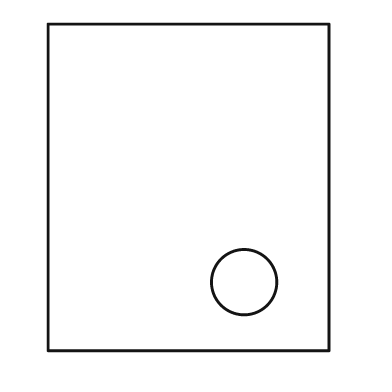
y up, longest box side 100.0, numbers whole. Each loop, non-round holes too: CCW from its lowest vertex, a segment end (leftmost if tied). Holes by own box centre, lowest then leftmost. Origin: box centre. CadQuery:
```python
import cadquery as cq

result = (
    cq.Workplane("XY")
    .moveTo(-43.0, -50.0)
    .lineTo(43.0, -50.0)
    .lineTo(43.0, 50.0)
    .lineTo(-43.0, 50.0)
    .close()
    .moveTo(17.0, -29.0)
    .circle(10.0)
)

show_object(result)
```